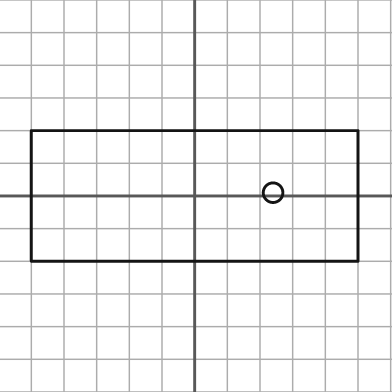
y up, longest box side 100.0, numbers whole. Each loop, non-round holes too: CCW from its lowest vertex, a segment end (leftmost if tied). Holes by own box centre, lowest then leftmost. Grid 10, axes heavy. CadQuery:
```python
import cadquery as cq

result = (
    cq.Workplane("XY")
    .moveTo(-50.0, -20.0)
    .lineTo(50.0, -20.0)
    .lineTo(50.0, 20.0)
    .lineTo(-50.0, 20.0)
    .close()
    .moveTo(24.0, 1.0)
    .circle(3.0)
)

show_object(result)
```